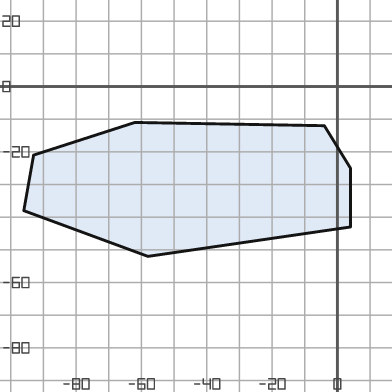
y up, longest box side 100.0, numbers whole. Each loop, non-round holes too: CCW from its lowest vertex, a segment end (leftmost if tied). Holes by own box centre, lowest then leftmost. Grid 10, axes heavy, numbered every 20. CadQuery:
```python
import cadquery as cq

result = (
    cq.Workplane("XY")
    .moveTo(-58.0, -52.0)
    .lineTo(4.0, -43.0)
    .lineTo(4.0, -25.0)
    .lineTo(-4.0, -12.0)
    .lineTo(-62.0, -11.0)
    .lineTo(-93.0, -21.0)
    .lineTo(-96.0, -38.0)
    .close()
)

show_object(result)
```